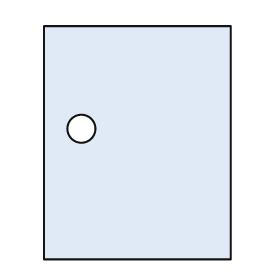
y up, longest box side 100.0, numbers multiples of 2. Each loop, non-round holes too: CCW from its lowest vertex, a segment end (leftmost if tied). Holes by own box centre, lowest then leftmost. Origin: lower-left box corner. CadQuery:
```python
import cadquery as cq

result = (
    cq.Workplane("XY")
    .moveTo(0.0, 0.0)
    .lineTo(80.0, 0.0)
    .lineTo(80.0, 100.0)
    .lineTo(0.0, 100.0)
    .close()
    .moveTo(16.0, 56.0)
    .circle(6.0)
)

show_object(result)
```